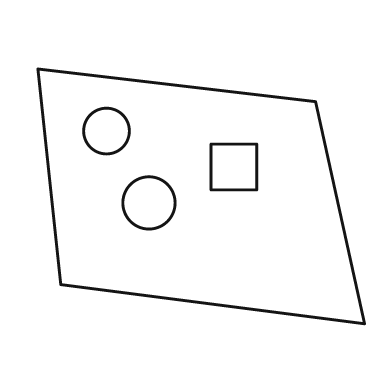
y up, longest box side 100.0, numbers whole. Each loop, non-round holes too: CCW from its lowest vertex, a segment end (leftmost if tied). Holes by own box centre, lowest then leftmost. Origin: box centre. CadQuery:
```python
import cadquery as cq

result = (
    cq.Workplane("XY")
    .moveTo(50.0, -39.0)
    .lineTo(35.0, 29.0)
    .lineTo(-50.0, 39.0)
    .lineTo(-43.0, -27.0)
    .close()
    .moveTo(-16.0, -2.0)
    .circle(8.0)
    .moveTo(3.0, 2.0)
    .lineTo(17.0, 2.0)
    .lineTo(17.0, 16.0)
    .lineTo(3.0, 16.0)
    .close()
    .moveTo(-29.0, 20.0)
    .circle(7.0)
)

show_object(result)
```